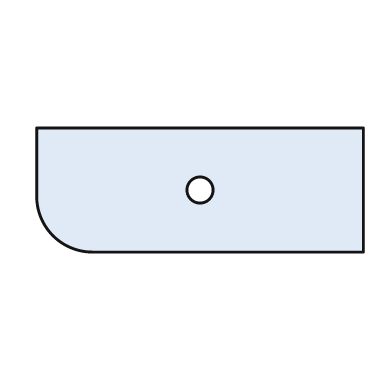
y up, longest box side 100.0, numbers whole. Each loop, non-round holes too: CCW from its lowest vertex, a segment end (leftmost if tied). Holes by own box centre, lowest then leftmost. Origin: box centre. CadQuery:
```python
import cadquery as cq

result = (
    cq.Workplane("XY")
    .moveTo(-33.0, -19.0)
    .lineTo(50.0, -19.0)
    .lineTo(50.0, 19.0)
    .lineTo(-50.0, 19.0)
    .lineTo(-50.0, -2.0)
    .threePointArc((-45.0, -14.0), (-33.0, -19.0))
    .close()
    .moveTo(0.0, 0.0)
    .circle(4.0)
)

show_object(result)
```